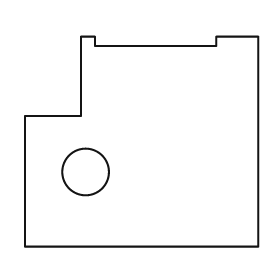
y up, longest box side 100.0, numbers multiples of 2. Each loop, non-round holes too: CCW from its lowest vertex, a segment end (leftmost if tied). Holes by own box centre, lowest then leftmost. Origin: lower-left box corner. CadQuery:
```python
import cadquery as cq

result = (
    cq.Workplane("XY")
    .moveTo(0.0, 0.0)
    .lineTo(100.0, 0.0)
    .lineTo(100.0, 90.0)
    .lineTo(82.0, 90.0)
    .lineTo(82.0, 86.0)
    .lineTo(30.0, 86.0)
    .lineTo(30.0, 90.0)
    .lineTo(24.0, 90.0)
    .lineTo(24.0, 56.0)
    .lineTo(0.0, 56.0)
    .close()
    .moveTo(26.0, 32.0)
    .circle(10.0)
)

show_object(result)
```